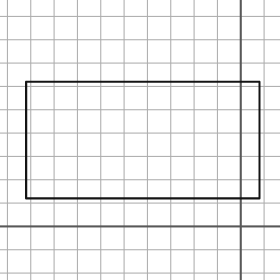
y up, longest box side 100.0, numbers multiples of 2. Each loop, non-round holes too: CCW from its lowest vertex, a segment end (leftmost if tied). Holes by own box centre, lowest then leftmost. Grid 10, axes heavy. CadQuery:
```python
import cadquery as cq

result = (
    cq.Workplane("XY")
    .moveTo(-92.0, 12.0)
    .lineTo(8.0, 12.0)
    .lineTo(8.0, 62.0)
    .lineTo(-92.0, 62.0)
    .close()
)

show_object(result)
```